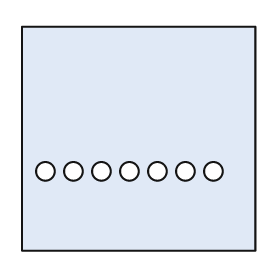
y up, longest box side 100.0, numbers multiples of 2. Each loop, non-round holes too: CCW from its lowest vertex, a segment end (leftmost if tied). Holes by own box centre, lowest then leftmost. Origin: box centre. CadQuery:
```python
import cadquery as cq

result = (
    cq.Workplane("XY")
    .moveTo(-50.0, -48.0)
    .lineTo(50.0, -48.0)
    .lineTo(50.0, 48.0)
    .lineTo(-50.0, 48.0)
    .close()
    .moveTo(-40.0, -14.0)
    .circle(4.0)
    .moveTo(-28.0, -14.0)
    .circle(4.0)
    .moveTo(-16.0, -14.0)
    .circle(4.0)
    .moveTo(-4.0, -14.0)
    .circle(4.0)
    .moveTo(8.0, -14.0)
    .circle(4.0)
    .moveTo(20.0, -14.0)
    .circle(4.0)
    .moveTo(32.0, -14.0)
    .circle(4.0)
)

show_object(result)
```